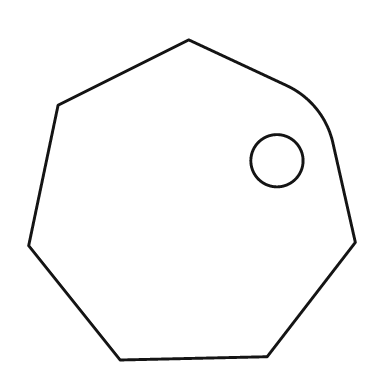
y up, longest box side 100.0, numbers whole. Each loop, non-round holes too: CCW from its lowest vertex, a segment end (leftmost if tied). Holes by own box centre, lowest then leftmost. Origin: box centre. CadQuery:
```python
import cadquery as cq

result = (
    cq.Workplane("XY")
    .moveTo(-22.0, -49.0)
    .lineTo(23.0, -48.0)
    .lineTo(50.0, -13.0)
    .lineTo(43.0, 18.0)
    .threePointArc((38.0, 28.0), (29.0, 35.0))
    .lineTo(-1.0, 49.0)
    .lineTo(-41.0, 29.0)
    .lineTo(-50.0, -14.0)
    .close()
    .moveTo(26.0, 12.0)
    .circle(8.0)
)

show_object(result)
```